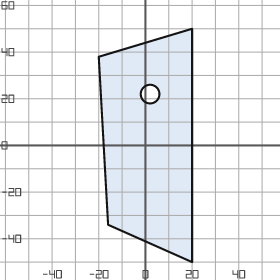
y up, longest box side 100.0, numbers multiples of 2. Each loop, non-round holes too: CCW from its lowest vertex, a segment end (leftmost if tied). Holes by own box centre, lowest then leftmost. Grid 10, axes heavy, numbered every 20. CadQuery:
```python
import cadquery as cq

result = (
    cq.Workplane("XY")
    .moveTo(20.0, -50.0)
    .lineTo(20.0, 50.0)
    .lineTo(-20.0, 38.0)
    .lineTo(-16.0, -34.0)
    .close()
    .moveTo(2.0, 22.0)
    .circle(4.0)
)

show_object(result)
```